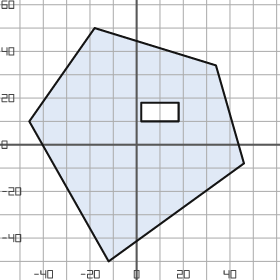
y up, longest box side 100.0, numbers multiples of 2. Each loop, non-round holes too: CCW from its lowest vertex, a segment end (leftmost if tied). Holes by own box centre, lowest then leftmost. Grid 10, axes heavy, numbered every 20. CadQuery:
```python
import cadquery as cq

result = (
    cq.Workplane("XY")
    .moveTo(-12.0, -50.0)
    .lineTo(46.0, -8.0)
    .lineTo(34.0, 34.0)
    .lineTo(-18.0, 50.0)
    .lineTo(-46.0, 10.0)
    .close()
    .moveTo(2.0, 10.0)
    .lineTo(18.0, 10.0)
    .lineTo(18.0, 18.0)
    .lineTo(2.0, 18.0)
    .close()
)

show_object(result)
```